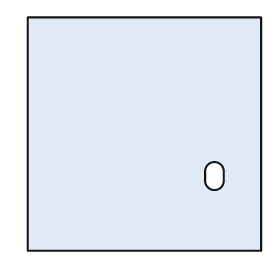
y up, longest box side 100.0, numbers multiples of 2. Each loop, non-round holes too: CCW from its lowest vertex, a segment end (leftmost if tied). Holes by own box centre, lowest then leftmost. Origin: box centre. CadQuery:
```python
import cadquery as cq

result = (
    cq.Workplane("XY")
    .moveTo(-50.0, -50.0)
    .lineTo(50.0, -50.0)
    .lineTo(50.0, 50.0)
    .lineTo(-50.0, 50.0)
    .close()
    .moveTo(26.0, -20.0)
    .threePointArc((30.0, -24.0), (34.0, -20.0))
    .lineTo(34.0, -16.0)
    .threePointArc((30.0, -12.0), (26.0, -16.0))
    .close()
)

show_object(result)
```